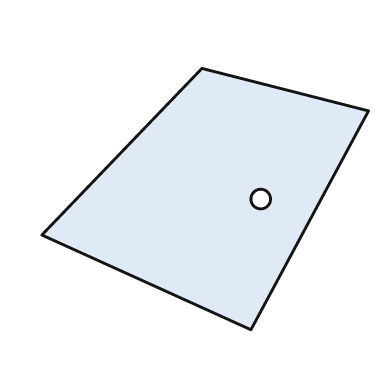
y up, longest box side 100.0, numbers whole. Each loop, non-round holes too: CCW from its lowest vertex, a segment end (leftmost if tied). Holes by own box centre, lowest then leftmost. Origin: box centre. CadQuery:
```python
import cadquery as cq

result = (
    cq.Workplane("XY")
    .moveTo(14.0, -40.0)
    .lineTo(50.0, 27.0)
    .lineTo(-1.0, 40.0)
    .lineTo(-50.0, -11.0)
    .close()
    .moveTo(17.0, 0.0)
    .circle(3.0)
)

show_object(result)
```